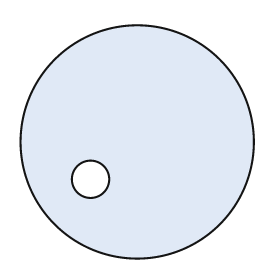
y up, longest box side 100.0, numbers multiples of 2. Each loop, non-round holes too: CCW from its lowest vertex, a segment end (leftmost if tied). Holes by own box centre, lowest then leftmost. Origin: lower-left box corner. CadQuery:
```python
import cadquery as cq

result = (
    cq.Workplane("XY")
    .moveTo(50.0, 50.0)
    .circle(50.0)
    .moveTo(30.0, 34.0)
    .circle(8.0)
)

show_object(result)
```